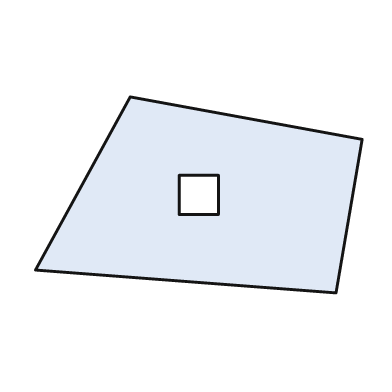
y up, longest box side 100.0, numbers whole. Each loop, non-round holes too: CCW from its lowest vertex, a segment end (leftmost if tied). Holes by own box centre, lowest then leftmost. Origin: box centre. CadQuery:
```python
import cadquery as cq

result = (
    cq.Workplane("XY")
    .moveTo(42.0, -30.0)
    .lineTo(50.0, 17.0)
    .lineTo(-21.0, 30.0)
    .lineTo(-50.0, -23.0)
    .close()
    .moveTo(-6.0, -6.0)
    .lineTo(6.0, -6.0)
    .lineTo(6.0, 6.0)
    .lineTo(-6.0, 6.0)
    .close()
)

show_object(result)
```